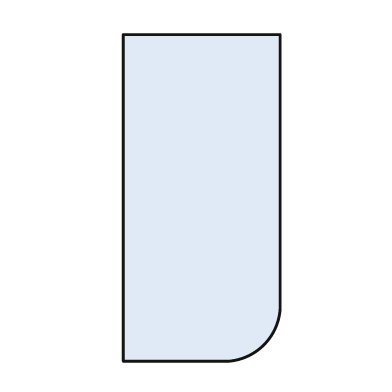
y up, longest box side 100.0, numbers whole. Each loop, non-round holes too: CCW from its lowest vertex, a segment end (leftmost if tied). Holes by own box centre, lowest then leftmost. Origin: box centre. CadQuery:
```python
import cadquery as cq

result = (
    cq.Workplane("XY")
    .moveTo(-24.0, -50.0)
    .lineTo(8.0, -50.0)
    .threePointArc((19.0, -45.0), (24.0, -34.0))
    .lineTo(24.0, 50.0)
    .lineTo(-24.0, 50.0)
    .close()
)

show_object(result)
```